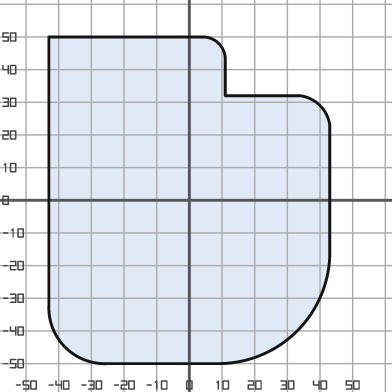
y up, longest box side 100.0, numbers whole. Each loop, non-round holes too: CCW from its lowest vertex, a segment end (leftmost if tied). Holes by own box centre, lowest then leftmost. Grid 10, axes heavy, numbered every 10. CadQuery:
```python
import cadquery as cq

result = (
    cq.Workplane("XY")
    .moveTo(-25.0, -50.0)
    .lineTo(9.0, -50.0)
    .threePointArc((33.0, -40.0), (43.0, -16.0))
    .lineTo(43.0, 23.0)
    .threePointArc((40.0, 29.0), (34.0, 32.0))
    .lineTo(11.0, 32.0)
    .lineTo(11.0, 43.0)
    .threePointArc((9.0, 48.0), (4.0, 50.0))
    .lineTo(-43.0, 50.0)
    .lineTo(-43.0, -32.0)
    .threePointArc((-38.0, -45.0), (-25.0, -50.0))
    .close()
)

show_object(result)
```